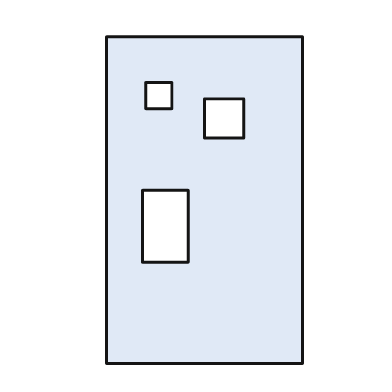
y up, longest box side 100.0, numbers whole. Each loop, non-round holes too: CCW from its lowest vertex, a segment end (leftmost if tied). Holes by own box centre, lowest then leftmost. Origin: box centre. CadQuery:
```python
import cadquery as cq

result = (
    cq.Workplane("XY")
    .moveTo(-30.0, -50.0)
    .lineTo(30.0, -50.0)
    .lineTo(30.0, 50.0)
    .lineTo(-30.0, 50.0)
    .close()
    .moveTo(-19.0, -19.0)
    .lineTo(-5.0, -19.0)
    .lineTo(-5.0, 3.0)
    .lineTo(-19.0, 3.0)
    .close()
    .moveTo(0.0, 19.0)
    .lineTo(12.0, 19.0)
    .lineTo(12.0, 31.0)
    .lineTo(0.0, 31.0)
    .close()
    .moveTo(-18.0, 28.0)
    .lineTo(-10.0, 28.0)
    .lineTo(-10.0, 36.0)
    .lineTo(-18.0, 36.0)
    .close()
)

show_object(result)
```